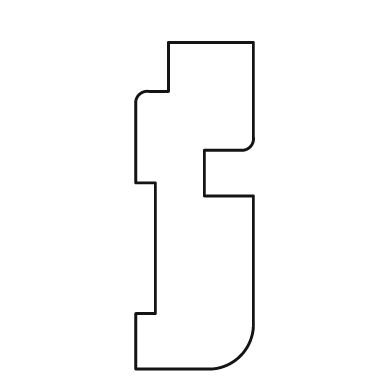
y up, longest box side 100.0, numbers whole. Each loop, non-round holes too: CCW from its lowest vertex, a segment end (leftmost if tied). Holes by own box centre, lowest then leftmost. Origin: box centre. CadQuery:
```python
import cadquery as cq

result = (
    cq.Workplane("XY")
    .moveTo(-18.0, -50.0)
    .lineTo(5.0, -50.0)
    .threePointArc((14.0, -46.0), (18.0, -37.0))
    .lineTo(18.0, 3.0)
    .lineTo(3.0, 3.0)
    .lineTo(3.0, 17.0)
    .lineTo(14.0, 17.0)
    .threePointArc((17.0, 18.0), (18.0, 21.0))
    .lineTo(18.0, 50.0)
    .lineTo(-8.0, 50.0)
    .lineTo(-8.0, 35.0)
    .lineTo(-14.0, 35.0)
    .threePointArc((-17.0, 34.0), (-18.0, 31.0))
    .lineTo(-18.0, 7.0)
    .lineTo(-12.0, 7.0)
    .lineTo(-12.0, -33.0)
    .lineTo(-18.0, -33.0)
    .close()
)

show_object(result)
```